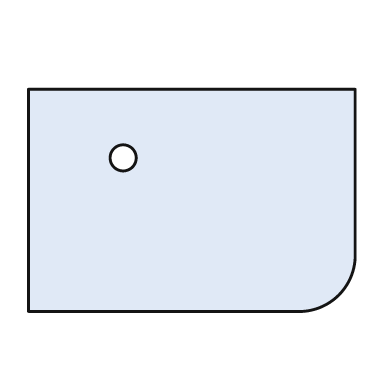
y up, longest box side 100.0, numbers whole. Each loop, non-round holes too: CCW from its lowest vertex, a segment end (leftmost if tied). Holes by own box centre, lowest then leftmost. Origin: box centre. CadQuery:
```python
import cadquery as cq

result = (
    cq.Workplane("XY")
    .moveTo(-50.0, -34.0)
    .lineTo(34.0, -34.0)
    .threePointArc((45.0, -29.0), (50.0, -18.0))
    .lineTo(50.0, 34.0)
    .lineTo(-50.0, 34.0)
    .close()
    .moveTo(-21.0, 13.0)
    .circle(4.0)
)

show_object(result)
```